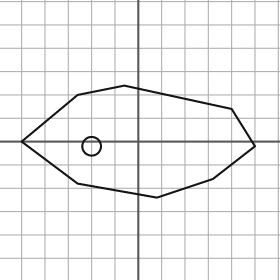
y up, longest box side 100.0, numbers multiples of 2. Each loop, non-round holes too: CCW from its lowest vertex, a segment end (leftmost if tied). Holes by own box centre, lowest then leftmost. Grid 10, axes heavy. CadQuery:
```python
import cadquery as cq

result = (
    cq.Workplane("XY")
    .moveTo(8.0, -24.0)
    .lineTo(32.0, -16.0)
    .lineTo(50.0, -2.0)
    .lineTo(40.0, 14.0)
    .lineTo(-6.0, 24.0)
    .lineTo(-26.0, 20.0)
    .lineTo(-50.0, 0.0)
    .lineTo(-26.0, -18.0)
    .close()
    .moveTo(-20.0, -2.0)
    .circle(4.0)
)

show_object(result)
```